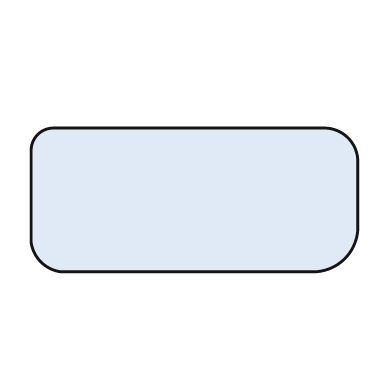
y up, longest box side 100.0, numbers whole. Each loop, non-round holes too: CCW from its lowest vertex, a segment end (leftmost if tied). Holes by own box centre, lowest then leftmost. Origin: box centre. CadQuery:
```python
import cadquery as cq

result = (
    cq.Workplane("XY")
    .moveTo(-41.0, -22.0)
    .lineTo(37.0, -22.0)
    .threePointArc((46.0, -18.0), (50.0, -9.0))
    .lineTo(50.0, 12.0)
    .threePointArc((47.0, 19.0), (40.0, 22.0))
    .lineTo(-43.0, 22.0)
    .threePointArc((-48.0, 20.0), (-50.0, 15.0))
    .lineTo(-50.0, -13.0)
    .threePointArc((-47.0, -19.0), (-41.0, -22.0))
    .close()
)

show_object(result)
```